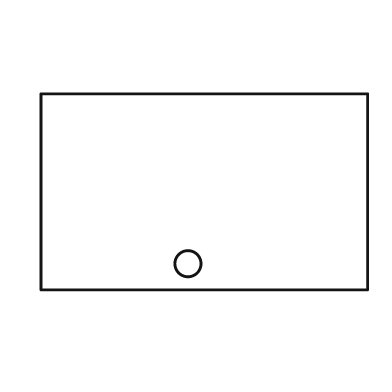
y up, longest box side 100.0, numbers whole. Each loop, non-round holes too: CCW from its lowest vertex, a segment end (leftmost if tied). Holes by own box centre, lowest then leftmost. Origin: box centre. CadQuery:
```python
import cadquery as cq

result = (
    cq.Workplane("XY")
    .moveTo(-50.0, -30.0)
    .lineTo(50.0, -30.0)
    .lineTo(50.0, 30.0)
    .lineTo(-50.0, 30.0)
    .close()
    .moveTo(-5.0, -22.0)
    .circle(4.0)
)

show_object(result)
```